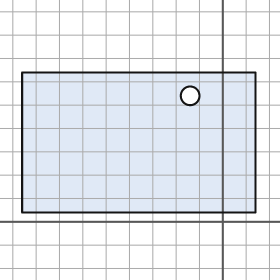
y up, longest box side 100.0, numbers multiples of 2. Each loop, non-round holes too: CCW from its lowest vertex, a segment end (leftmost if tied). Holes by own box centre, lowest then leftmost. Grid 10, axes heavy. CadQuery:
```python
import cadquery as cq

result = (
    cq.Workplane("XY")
    .moveTo(-86.0, 4.0)
    .lineTo(14.0, 4.0)
    .lineTo(14.0, 64.0)
    .lineTo(-86.0, 64.0)
    .close()
    .moveTo(-14.0, 54.0)
    .circle(4.0)
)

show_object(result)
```